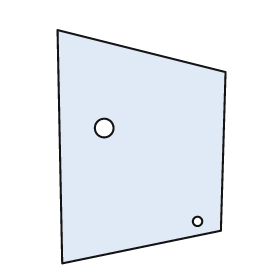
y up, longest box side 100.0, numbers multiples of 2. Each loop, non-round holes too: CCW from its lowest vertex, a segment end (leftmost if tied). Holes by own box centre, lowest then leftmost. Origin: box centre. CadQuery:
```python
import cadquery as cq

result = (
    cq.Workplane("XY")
    .moveTo(-34.0, -50.0)
    .lineTo(34.0, -36.0)
    .lineTo(36.0, 32.0)
    .lineTo(-36.0, 50.0)
    .close()
    .moveTo(24.0, -32.0)
    .circle(2.0)
    .moveTo(-16.0, 8.0)
    .circle(4.0)
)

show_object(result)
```